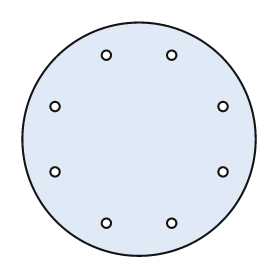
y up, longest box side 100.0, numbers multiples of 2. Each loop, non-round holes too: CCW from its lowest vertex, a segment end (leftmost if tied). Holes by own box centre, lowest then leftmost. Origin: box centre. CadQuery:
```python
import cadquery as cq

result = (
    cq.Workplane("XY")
    .moveTo(0.0, 0.0)
    .circle(50.0)
    .moveTo(-14.0, -36.0)
    .circle(2.0)
    .moveTo(14.0, -36.0)
    .circle(2.0)
    .moveTo(-36.0, -14.0)
    .circle(2.0)
    .moveTo(36.0, -14.0)
    .circle(2.0)
    .moveTo(-36.0, 14.0)
    .circle(2.0)
    .moveTo(36.0, 14.0)
    .circle(2.0)
    .moveTo(-14.0, 36.0)
    .circle(2.0)
    .moveTo(14.0, 36.0)
    .circle(2.0)
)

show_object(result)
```